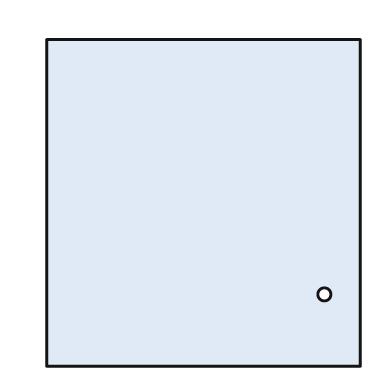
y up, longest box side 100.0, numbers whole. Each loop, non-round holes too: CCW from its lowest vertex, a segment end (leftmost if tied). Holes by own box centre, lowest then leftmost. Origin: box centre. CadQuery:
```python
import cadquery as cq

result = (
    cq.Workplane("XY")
    .moveTo(-48.0, -50.0)
    .lineTo(48.0, -50.0)
    .lineTo(48.0, 50.0)
    .lineTo(-48.0, 50.0)
    .close()
    .moveTo(37.0, -28.0)
    .circle(2.0)
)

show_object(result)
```